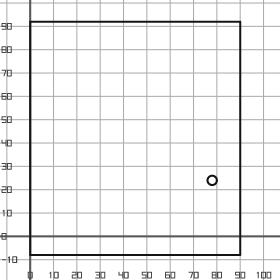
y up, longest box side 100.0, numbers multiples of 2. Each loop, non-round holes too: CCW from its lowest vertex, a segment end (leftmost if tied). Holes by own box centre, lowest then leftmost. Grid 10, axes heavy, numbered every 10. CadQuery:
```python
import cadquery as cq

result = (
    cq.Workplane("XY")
    .moveTo(0.0, -8.0)
    .lineTo(90.0, -8.0)
    .lineTo(90.0, 92.0)
    .lineTo(0.0, 92.0)
    .close()
    .moveTo(78.0, 24.0)
    .circle(2.0)
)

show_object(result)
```